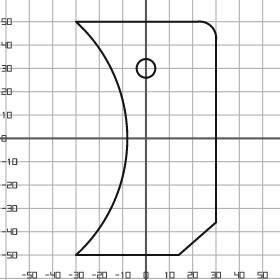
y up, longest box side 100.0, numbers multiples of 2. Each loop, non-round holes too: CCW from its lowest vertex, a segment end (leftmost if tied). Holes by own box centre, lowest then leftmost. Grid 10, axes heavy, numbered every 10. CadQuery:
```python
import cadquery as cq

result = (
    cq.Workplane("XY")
    .moveTo(-30.0, -50.0)
    .lineTo(14.0, -50.0)
    .lineTo(30.0, -36.0)
    .lineTo(30.0, 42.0)
    .threePointArc((28.0, 48.0), (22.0, 50.0))
    .lineTo(-30.0, 50.0)
    .threePointArc((-8.0, 0.0), (-30.0, -50.0))
    .close()
    .moveTo(0.0, 30.0)
    .circle(4.0)
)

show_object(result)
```